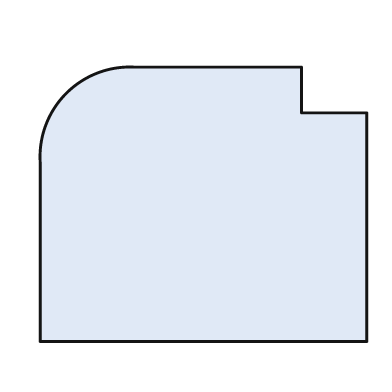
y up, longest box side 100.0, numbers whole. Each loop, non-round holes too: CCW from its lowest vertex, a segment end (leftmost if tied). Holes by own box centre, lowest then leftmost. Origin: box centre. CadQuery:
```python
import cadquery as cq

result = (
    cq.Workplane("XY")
    .moveTo(-50.0, -42.0)
    .lineTo(50.0, -42.0)
    .lineTo(50.0, 28.0)
    .lineTo(30.0, 28.0)
    .lineTo(30.0, 42.0)
    .lineTo(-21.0, 42.0)
    .threePointArc((-42.0, 34.0), (-50.0, 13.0))
    .close()
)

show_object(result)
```